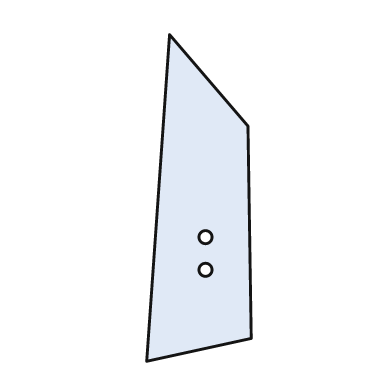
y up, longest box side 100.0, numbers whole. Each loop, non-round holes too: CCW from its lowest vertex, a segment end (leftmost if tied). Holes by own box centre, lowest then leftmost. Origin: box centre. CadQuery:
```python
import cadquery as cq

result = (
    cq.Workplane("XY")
    .moveTo(-16.0, -50.0)
    .lineTo(16.0, -43.0)
    .lineTo(15.0, 22.0)
    .lineTo(-9.0, 50.0)
    .close()
    .moveTo(2.0, -22.0)
    .circle(2.0)
    .moveTo(2.0, -12.0)
    .circle(2.0)
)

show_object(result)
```